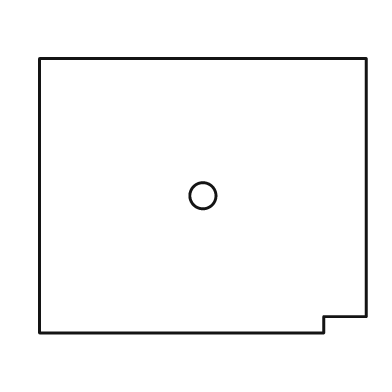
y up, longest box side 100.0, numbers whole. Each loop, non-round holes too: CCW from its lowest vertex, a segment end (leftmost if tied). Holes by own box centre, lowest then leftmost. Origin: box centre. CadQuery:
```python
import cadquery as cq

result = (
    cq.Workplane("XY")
    .moveTo(-50.0, -42.0)
    .lineTo(37.0, -42.0)
    .lineTo(37.0, -37.0)
    .lineTo(50.0, -37.0)
    .lineTo(50.0, 42.0)
    .lineTo(-50.0, 42.0)
    .close()
    .moveTo(0.0, 0.0)
    .circle(4.0)
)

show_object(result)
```